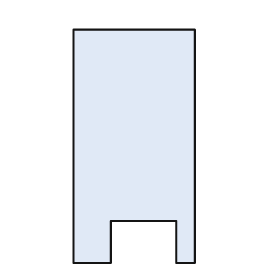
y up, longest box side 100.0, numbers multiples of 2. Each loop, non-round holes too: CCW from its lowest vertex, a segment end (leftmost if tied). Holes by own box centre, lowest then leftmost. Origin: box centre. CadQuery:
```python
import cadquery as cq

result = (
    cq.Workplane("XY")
    .moveTo(-26.0, -50.0)
    .lineTo(-10.0, -50.0)
    .lineTo(-10.0, -32.0)
    .lineTo(18.0, -32.0)
    .lineTo(18.0, -50.0)
    .lineTo(26.0, -50.0)
    .lineTo(26.0, 50.0)
    .lineTo(-26.0, 50.0)
    .close()
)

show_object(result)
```